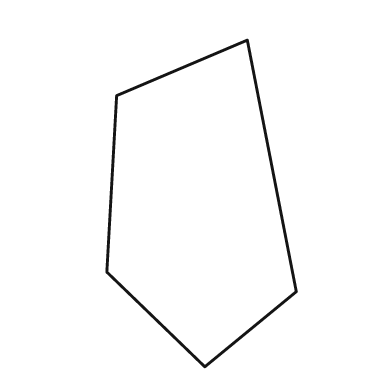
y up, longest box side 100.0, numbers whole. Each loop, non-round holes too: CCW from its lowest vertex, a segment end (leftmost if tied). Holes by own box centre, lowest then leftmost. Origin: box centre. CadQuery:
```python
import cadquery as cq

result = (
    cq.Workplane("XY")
    .moveTo(1.0, -50.0)
    .lineTo(29.0, -27.0)
    .lineTo(14.0, 50.0)
    .lineTo(-26.0, 33.0)
    .lineTo(-29.0, -21.0)
    .close()
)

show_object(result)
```